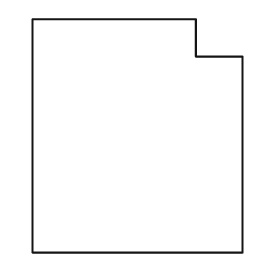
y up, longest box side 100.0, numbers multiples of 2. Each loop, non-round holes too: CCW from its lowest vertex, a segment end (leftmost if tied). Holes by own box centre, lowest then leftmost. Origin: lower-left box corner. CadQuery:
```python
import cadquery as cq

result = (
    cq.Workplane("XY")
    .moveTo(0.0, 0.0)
    .lineTo(90.0, 0.0)
    .lineTo(90.0, 84.0)
    .lineTo(70.0, 84.0)
    .lineTo(70.0, 100.0)
    .lineTo(0.0, 100.0)
    .close()
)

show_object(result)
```